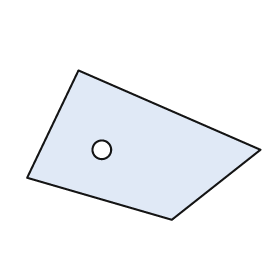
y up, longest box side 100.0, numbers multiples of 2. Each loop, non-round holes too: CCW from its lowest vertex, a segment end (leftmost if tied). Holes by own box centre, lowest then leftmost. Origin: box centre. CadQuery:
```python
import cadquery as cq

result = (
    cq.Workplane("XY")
    .moveTo(12.0, -32.0)
    .lineTo(50.0, -2.0)
    .lineTo(-28.0, 32.0)
    .lineTo(-50.0, -14.0)
    .close()
    .moveTo(-18.0, -2.0)
    .circle(4.0)
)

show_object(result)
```